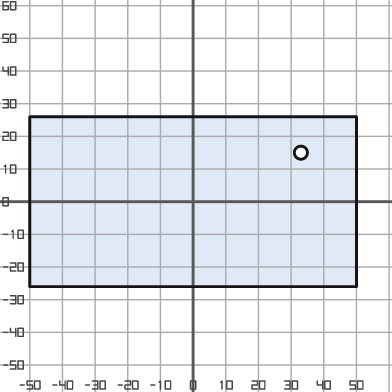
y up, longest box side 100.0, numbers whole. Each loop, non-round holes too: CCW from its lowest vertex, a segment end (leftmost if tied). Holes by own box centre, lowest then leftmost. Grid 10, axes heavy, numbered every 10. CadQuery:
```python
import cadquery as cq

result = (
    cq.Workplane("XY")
    .moveTo(-50.0, -26.0)
    .lineTo(50.0, -26.0)
    .lineTo(50.0, 26.0)
    .lineTo(-50.0, 26.0)
    .close()
    .moveTo(33.0, 15.0)
    .circle(2.0)
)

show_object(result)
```